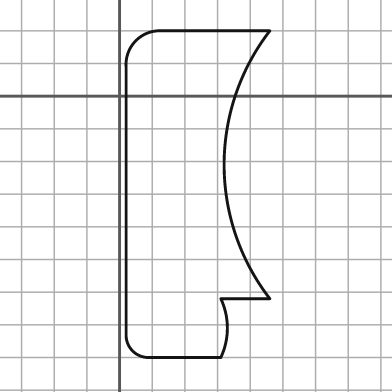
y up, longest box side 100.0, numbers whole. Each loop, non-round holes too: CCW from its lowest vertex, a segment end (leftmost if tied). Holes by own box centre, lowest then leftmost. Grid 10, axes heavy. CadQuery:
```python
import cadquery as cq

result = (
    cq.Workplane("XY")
    .moveTo(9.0, -80.0)
    .lineTo(31.0, -80.0)
    .threePointArc((33.0, -71.0), (31.0, -62.0))
    .lineTo(46.0, -62.0)
    .threePointArc((32.0, -21.0), (46.0, 20.0))
    .lineTo(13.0, 20.0)
    .threePointArc((5.0, 17.0), (2.0, 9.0))
    .lineTo(2.0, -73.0)
    .threePointArc((4.0, -78.0), (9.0, -80.0))
    .close()
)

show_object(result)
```